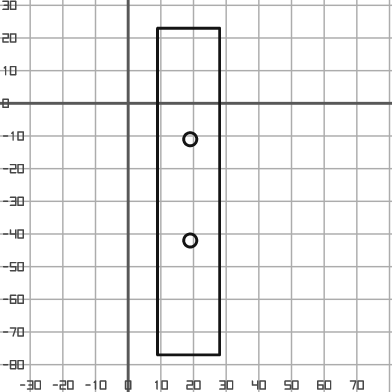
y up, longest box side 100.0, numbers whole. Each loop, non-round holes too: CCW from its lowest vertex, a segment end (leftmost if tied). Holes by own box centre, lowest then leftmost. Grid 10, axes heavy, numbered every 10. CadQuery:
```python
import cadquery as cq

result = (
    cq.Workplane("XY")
    .moveTo(9.0, -77.0)
    .lineTo(28.0, -77.0)
    .lineTo(28.0, 23.0)
    .lineTo(9.0, 23.0)
    .close()
    .moveTo(19.0, -42.0)
    .circle(2.0)
    .moveTo(19.0, -11.0)
    .circle(2.0)
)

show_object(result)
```